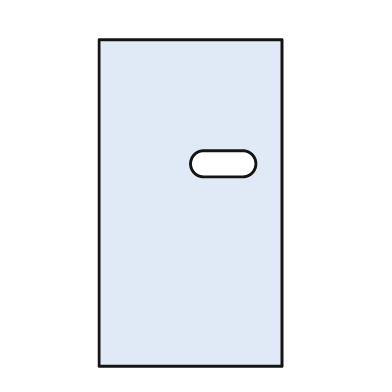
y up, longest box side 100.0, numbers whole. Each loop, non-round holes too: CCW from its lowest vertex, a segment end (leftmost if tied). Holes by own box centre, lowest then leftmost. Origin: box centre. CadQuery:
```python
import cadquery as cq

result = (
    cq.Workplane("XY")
    .moveTo(-28.0, -50.0)
    .lineTo(28.0, -50.0)
    .lineTo(28.0, 50.0)
    .lineTo(-28.0, 50.0)
    .close()
    .moveTo(4.0, 8.0)
    .lineTo(16.0, 8.0)
    .threePointArc((20.0, 12.0), (16.0, 16.0))
    .lineTo(4.0, 16.0)
    .threePointArc((0.0, 12.0), (4.0, 8.0))
    .close()
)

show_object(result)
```